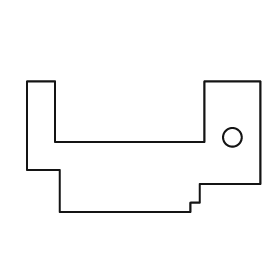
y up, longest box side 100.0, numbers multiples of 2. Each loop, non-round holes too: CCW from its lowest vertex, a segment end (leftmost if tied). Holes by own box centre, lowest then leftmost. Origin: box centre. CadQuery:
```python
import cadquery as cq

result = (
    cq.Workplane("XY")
    .moveTo(-36.0, -28.0)
    .lineTo(20.0, -28.0)
    .lineTo(20.0, -24.0)
    .lineTo(24.0, -24.0)
    .lineTo(24.0, -16.0)
    .lineTo(50.0, -16.0)
    .lineTo(50.0, 28.0)
    .lineTo(26.0, 28.0)
    .lineTo(26.0, 2.0)
    .lineTo(-38.0, 2.0)
    .lineTo(-38.0, 28.0)
    .lineTo(-50.0, 28.0)
    .lineTo(-50.0, -10.0)
    .lineTo(-36.0, -10.0)
    .close()
    .moveTo(38.0, 4.0)
    .circle(4.0)
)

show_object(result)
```